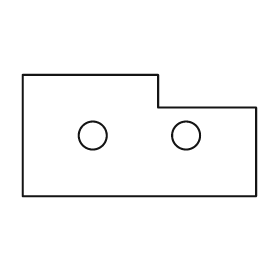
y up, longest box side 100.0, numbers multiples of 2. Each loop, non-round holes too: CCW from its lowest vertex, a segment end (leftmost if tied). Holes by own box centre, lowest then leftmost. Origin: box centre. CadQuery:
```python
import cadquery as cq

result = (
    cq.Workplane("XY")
    .moveTo(-50.0, -26.0)
    .lineTo(50.0, -26.0)
    .lineTo(50.0, 12.0)
    .lineTo(8.0, 12.0)
    .lineTo(8.0, 26.0)
    .lineTo(-50.0, 26.0)
    .close()
    .moveTo(-20.0, 0.0)
    .circle(6.0)
    .moveTo(20.0, 0.0)
    .circle(6.0)
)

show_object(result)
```